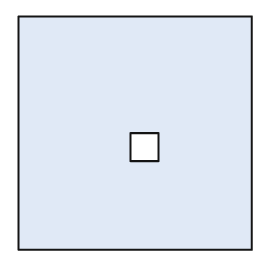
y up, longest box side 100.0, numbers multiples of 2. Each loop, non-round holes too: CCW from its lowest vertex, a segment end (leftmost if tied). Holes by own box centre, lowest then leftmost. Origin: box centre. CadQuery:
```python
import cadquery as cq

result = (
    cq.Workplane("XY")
    .moveTo(-50.0, -50.0)
    .lineTo(50.0, -50.0)
    .lineTo(50.0, 50.0)
    .lineTo(-50.0, 50.0)
    .close()
    .moveTo(-2.0, -12.0)
    .lineTo(10.0, -12.0)
    .lineTo(10.0, 0.0)
    .lineTo(-2.0, 0.0)
    .close()
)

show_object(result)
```